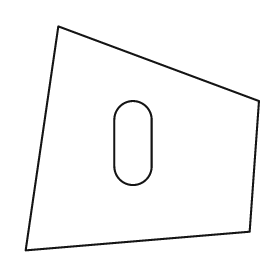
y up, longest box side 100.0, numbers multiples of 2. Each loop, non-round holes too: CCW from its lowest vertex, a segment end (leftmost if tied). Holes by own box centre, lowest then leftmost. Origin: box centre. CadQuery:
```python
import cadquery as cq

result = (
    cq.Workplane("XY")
    .moveTo(-50.0, -48.0)
    .lineTo(46.0, -40.0)
    .lineTo(50.0, 16.0)
    .lineTo(-36.0, 48.0)
    .close()
    .moveTo(-12.0, -12.0)
    .threePointArc((-4.0, -20.0), (4.0, -12.0))
    .lineTo(4.0, 8.0)
    .threePointArc((-4.0, 16.0), (-12.0, 8.0))
    .close()
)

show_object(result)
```